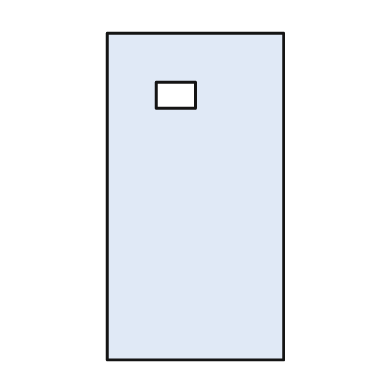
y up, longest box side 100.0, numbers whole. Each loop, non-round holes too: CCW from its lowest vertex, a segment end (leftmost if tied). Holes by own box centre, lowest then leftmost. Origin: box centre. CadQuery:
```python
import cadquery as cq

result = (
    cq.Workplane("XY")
    .moveTo(-27.0, -50.0)
    .lineTo(27.0, -50.0)
    .lineTo(27.0, 50.0)
    .lineTo(-27.0, 50.0)
    .close()
    .moveTo(-12.0, 27.0)
    .lineTo(0.0, 27.0)
    .lineTo(0.0, 35.0)
    .lineTo(-12.0, 35.0)
    .close()
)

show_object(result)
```